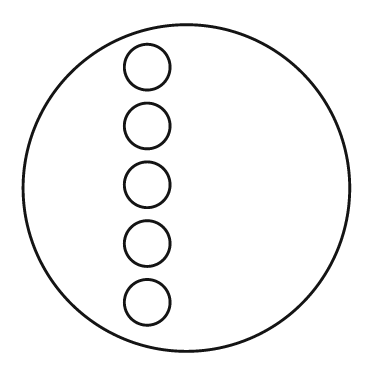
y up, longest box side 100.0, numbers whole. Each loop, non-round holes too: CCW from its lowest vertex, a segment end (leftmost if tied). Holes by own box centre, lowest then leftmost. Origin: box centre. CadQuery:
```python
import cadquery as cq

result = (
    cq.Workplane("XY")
    .moveTo(0.0, 0.0)
    .circle(50.0)
    .moveTo(-12.0, -35.0)
    .circle(7.0)
    .moveTo(-12.0, -17.0)
    .circle(7.0)
    .moveTo(-12.0, 1.0)
    .circle(7.0)
    .moveTo(-12.0, 19.0)
    .circle(7.0)
    .moveTo(-12.0, 37.0)
    .circle(7.0)
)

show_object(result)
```